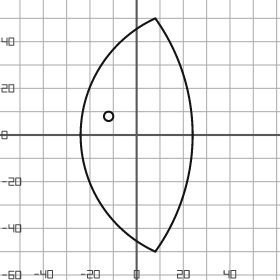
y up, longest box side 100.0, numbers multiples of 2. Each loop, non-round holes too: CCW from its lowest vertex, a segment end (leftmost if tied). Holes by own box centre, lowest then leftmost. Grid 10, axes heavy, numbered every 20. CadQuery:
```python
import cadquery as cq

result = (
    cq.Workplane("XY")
    .moveTo(8.0, -50.0)
    .threePointArc((24.0, 0.0), (8.0, 50.0))
    .threePointArc((-24.0, 0.0), (8.0, -50.0))
    .close()
    .moveTo(-12.0, 8.0)
    .circle(2.0)
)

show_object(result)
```